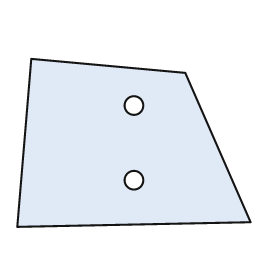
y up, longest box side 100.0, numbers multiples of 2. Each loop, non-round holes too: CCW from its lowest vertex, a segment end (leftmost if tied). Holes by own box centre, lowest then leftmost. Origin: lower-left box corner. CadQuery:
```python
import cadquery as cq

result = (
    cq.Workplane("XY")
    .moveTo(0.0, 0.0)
    .lineTo(100.0, 2.0)
    .lineTo(72.0, 66.0)
    .lineTo(6.0, 72.0)
    .close()
    .moveTo(50.0, 20.0)
    .circle(4.0)
    .moveTo(50.0, 52.0)
    .circle(4.0)
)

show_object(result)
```